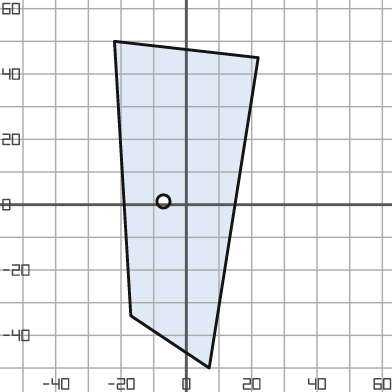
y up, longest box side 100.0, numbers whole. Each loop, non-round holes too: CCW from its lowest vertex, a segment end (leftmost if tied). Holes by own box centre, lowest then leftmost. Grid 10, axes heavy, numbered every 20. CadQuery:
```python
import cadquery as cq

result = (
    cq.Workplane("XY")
    .moveTo(7.0, -50.0)
    .lineTo(22.0, 45.0)
    .lineTo(-22.0, 50.0)
    .lineTo(-17.0, -34.0)
    .close()
    .moveTo(-7.0, 1.0)
    .circle(2.0)
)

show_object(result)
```